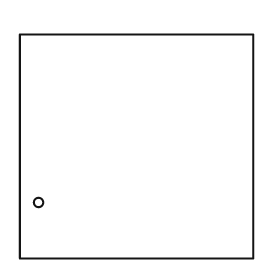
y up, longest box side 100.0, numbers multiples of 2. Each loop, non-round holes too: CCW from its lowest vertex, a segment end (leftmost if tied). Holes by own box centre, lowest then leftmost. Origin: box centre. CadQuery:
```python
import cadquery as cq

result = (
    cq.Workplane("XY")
    .moveTo(-50.0, -48.0)
    .lineTo(50.0, -48.0)
    .lineTo(50.0, 48.0)
    .lineTo(-50.0, 48.0)
    .close()
    .moveTo(-42.0, -24.0)
    .circle(2.0)
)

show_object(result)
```